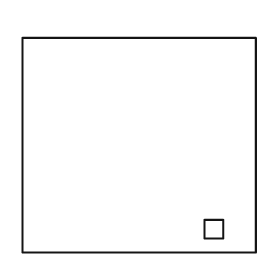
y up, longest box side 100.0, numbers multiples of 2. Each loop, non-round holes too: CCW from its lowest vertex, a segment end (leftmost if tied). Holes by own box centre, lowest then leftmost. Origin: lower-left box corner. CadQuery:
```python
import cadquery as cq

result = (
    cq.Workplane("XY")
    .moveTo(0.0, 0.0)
    .lineTo(100.0, 0.0)
    .lineTo(100.0, 92.0)
    .lineTo(0.0, 92.0)
    .close()
    .moveTo(78.0, 6.0)
    .lineTo(86.0, 6.0)
    .lineTo(86.0, 14.0)
    .lineTo(78.0, 14.0)
    .close()
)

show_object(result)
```